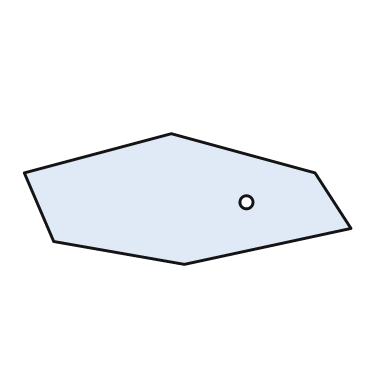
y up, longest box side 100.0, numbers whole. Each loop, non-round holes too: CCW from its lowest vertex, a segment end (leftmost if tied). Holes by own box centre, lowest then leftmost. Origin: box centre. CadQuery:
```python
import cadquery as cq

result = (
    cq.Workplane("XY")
    .moveTo(-1.0, -20.0)
    .lineTo(50.0, -9.0)
    .lineTo(39.0, 8.0)
    .lineTo(-5.0, 20.0)
    .lineTo(-50.0, 8.0)
    .lineTo(-41.0, -13.0)
    .close()
    .moveTo(18.0, -1.0)
    .circle(2.0)
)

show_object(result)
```